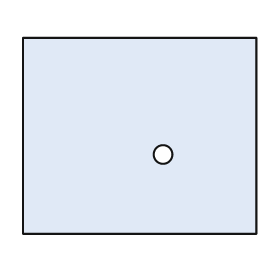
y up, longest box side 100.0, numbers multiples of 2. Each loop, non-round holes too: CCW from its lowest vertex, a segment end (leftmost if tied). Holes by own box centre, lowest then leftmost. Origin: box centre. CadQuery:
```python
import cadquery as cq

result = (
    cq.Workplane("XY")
    .moveTo(-50.0, -42.0)
    .lineTo(50.0, -42.0)
    .lineTo(50.0, 42.0)
    .lineTo(-50.0, 42.0)
    .close()
    .moveTo(10.0, -8.0)
    .circle(4.0)
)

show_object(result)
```